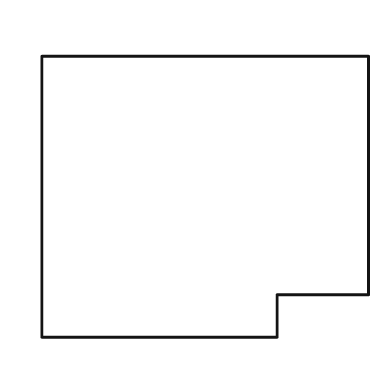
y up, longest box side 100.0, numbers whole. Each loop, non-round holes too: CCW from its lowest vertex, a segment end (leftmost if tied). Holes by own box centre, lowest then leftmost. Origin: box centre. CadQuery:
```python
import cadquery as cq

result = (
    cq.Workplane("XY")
    .moveTo(-50.0, -43.0)
    .lineTo(22.0, -43.0)
    .lineTo(22.0, -30.0)
    .lineTo(50.0, -30.0)
    .lineTo(50.0, 43.0)
    .lineTo(-50.0, 43.0)
    .close()
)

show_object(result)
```